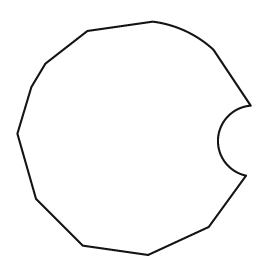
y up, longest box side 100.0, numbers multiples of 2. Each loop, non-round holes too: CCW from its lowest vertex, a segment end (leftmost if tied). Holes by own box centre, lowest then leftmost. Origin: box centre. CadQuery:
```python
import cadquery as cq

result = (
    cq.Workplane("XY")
    .moveTo(6.0, -50.0)
    .lineTo(32.0, -38.0)
    .lineTo(48.0, -16.0)
    .threePointArc((36.0, 0.0), (50.0, 14.0))
    .lineTo(34.0, 38.0)
    .threePointArc((22.0, 46.0), (8.0, 50.0))
    .lineTo(-20.0, 46.0)
    .lineTo(-38.0, 32.0)
    .lineTo(-44.0, 22.0)
    .lineTo(-50.0, 2.0)
    .lineTo(-42.0, -26.0)
    .lineTo(-22.0, -46.0)
    .close()
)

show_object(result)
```